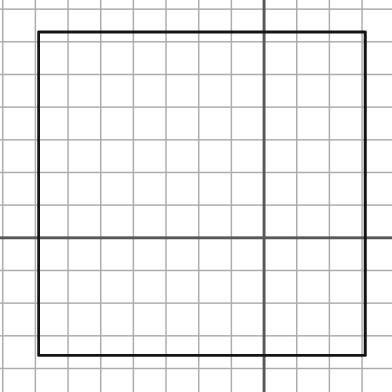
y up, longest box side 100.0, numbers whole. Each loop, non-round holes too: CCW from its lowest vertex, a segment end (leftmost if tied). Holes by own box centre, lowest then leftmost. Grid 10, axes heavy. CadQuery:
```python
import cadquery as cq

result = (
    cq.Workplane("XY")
    .moveTo(-69.0, -36.0)
    .lineTo(31.0, -36.0)
    .lineTo(31.0, 63.0)
    .lineTo(-69.0, 63.0)
    .close()
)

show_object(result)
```